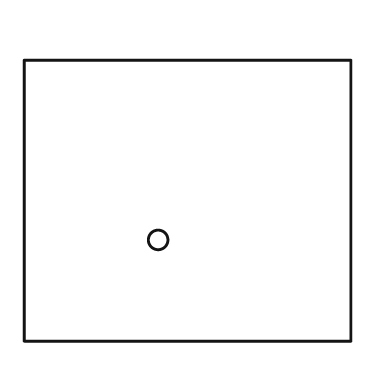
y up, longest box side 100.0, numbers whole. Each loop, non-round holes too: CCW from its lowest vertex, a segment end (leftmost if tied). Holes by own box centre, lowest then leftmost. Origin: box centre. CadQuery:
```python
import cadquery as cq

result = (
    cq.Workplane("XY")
    .moveTo(-50.0, -43.0)
    .lineTo(50.0, -43.0)
    .lineTo(50.0, 43.0)
    .lineTo(-50.0, 43.0)
    .close()
    .moveTo(-9.0, -12.0)
    .circle(3.0)
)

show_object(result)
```